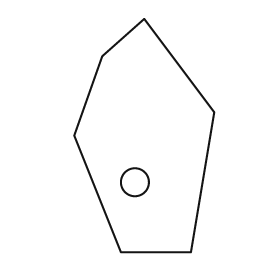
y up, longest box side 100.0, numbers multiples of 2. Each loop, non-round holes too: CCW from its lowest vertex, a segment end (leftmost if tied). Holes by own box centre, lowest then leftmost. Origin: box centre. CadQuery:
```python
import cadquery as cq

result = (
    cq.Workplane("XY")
    .moveTo(-10.0, -50.0)
    .lineTo(20.0, -50.0)
    .lineTo(30.0, 10.0)
    .lineTo(0.0, 50.0)
    .lineTo(-18.0, 34.0)
    .lineTo(-30.0, 0.0)
    .close()
    .moveTo(-4.0, -20.0)
    .circle(6.0)
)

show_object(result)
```